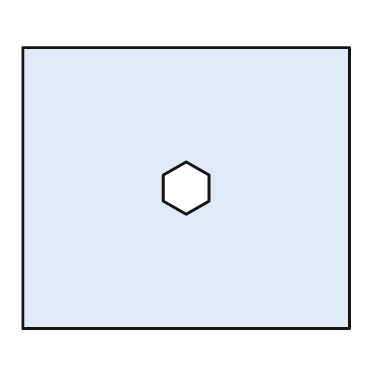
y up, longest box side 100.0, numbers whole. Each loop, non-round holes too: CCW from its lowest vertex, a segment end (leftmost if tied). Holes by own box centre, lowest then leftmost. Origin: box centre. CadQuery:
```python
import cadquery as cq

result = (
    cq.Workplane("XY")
    .moveTo(-50.0, -43.0)
    .lineTo(50.0, -43.0)
    .lineTo(50.0, 43.0)
    .lineTo(-50.0, 43.0)
    .close()
    .moveTo(0.0, -8.0)
    .lineTo(7.0, -4.0)
    .lineTo(7.0, 4.0)
    .lineTo(0.0, 8.0)
    .lineTo(-7.0, 4.0)
    .lineTo(-7.0, -4.0)
    .close()
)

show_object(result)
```